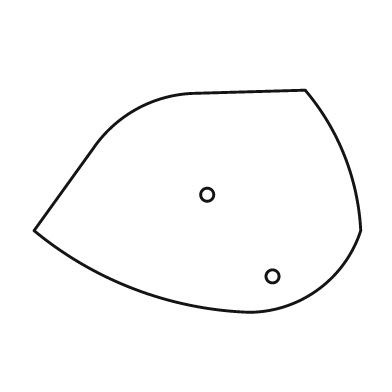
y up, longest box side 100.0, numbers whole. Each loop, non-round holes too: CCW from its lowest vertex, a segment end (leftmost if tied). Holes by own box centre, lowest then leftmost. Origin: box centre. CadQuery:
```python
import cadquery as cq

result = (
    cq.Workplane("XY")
    .moveTo(16.0, -34.0)
    .threePointArc((37.0, -27.0), (50.0, -9.0))
    .threePointArc((45.0, 14.0), (33.0, 34.0))
    .lineTo(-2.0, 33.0)
    .threePointArc((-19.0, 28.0), (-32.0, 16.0))
    .lineTo(-50.0, -9.0)
    .threePointArc((-19.0, -27.0), (16.0, -34.0))
    .close()
    .moveTo(23.0, -23.0)
    .circle(2.0)
    .moveTo(3.0, 2.0)
    .circle(2.0)
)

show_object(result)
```